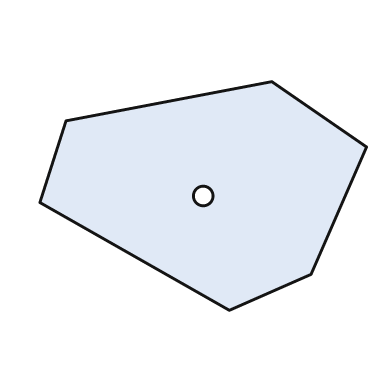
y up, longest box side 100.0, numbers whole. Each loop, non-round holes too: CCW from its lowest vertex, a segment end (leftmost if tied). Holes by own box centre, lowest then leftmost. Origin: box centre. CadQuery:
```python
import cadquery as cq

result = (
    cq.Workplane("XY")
    .moveTo(8.0, -35.0)
    .lineTo(33.0, -24.0)
    .lineTo(50.0, 15.0)
    .lineTo(21.0, 35.0)
    .lineTo(-42.0, 23.0)
    .lineTo(-50.0, -2.0)
    .close()
    .moveTo(0.0, 0.0)
    .circle(3.0)
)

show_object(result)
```